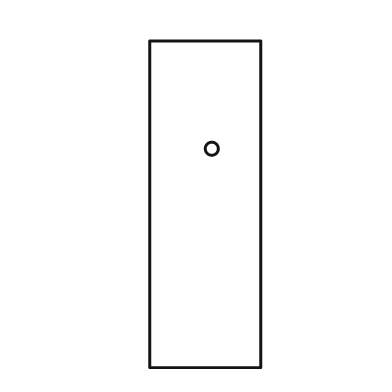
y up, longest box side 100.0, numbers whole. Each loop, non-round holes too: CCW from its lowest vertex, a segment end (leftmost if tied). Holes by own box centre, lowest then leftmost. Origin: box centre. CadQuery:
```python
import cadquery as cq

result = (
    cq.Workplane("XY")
    .moveTo(-17.0, -50.0)
    .lineTo(17.0, -50.0)
    .lineTo(17.0, 50.0)
    .lineTo(-17.0, 50.0)
    .close()
    .moveTo(2.0, 17.0)
    .circle(2.0)
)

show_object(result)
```